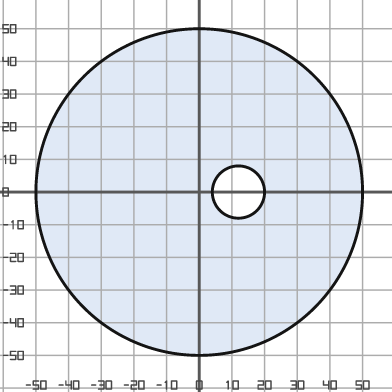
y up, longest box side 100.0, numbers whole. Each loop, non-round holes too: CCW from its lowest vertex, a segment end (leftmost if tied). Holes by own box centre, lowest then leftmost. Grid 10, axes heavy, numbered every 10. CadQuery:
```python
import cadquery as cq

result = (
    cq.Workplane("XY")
    .moveTo(0.0, 0.0)
    .circle(50.0)
    .moveTo(12.0, 0.0)
    .circle(8.0)
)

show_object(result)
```